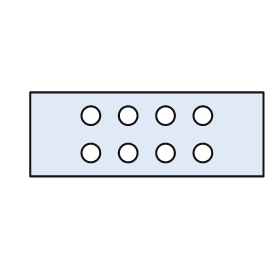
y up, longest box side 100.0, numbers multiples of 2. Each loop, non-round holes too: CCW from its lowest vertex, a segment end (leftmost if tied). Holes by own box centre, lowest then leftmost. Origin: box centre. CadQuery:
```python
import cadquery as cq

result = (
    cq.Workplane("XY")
    .moveTo(-50.0, -18.0)
    .lineTo(50.0, -18.0)
    .lineTo(50.0, 18.0)
    .lineTo(-50.0, 18.0)
    .close()
    .moveTo(-24.0, -8.0)
    .circle(4.0)
    .moveTo(-8.0, -8.0)
    .circle(4.0)
    .moveTo(8.0, -8.0)
    .circle(4.0)
    .moveTo(24.0, -8.0)
    .circle(4.0)
    .moveTo(-24.0, 8.0)
    .circle(4.0)
    .moveTo(-8.0, 8.0)
    .circle(4.0)
    .moveTo(8.0, 8.0)
    .circle(4.0)
    .moveTo(24.0, 8.0)
    .circle(4.0)
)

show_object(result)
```